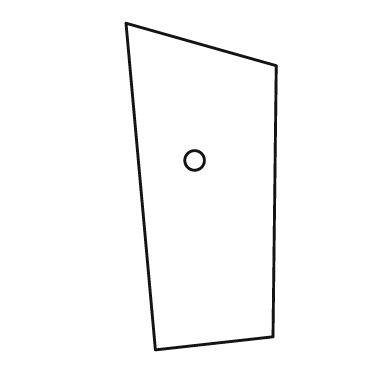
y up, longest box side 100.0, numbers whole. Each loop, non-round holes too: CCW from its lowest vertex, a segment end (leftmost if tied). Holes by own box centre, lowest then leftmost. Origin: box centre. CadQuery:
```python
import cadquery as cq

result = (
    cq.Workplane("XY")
    .moveTo(-14.0, -50.0)
    .lineTo(22.0, -46.0)
    .lineTo(23.0, 37.0)
    .lineTo(-23.0, 50.0)
    .close()
    .moveTo(-2.0, 8.0)
    .circle(3.0)
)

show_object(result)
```